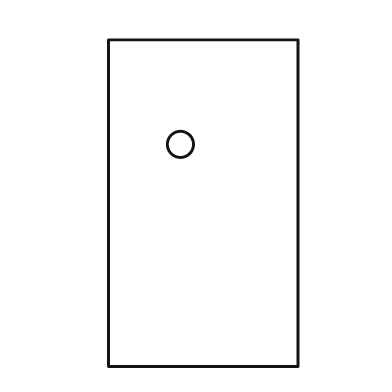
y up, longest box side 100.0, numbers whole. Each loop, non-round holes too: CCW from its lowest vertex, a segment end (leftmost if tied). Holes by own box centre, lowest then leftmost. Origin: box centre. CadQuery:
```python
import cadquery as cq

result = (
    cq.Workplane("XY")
    .moveTo(-29.0, -50.0)
    .lineTo(29.0, -50.0)
    .lineTo(29.0, 50.0)
    .lineTo(-29.0, 50.0)
    .close()
    .moveTo(-7.0, 18.0)
    .circle(4.0)
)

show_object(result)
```